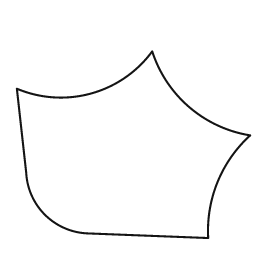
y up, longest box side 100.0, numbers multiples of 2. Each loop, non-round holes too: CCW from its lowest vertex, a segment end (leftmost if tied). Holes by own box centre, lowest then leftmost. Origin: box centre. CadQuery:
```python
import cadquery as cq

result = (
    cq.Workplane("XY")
    .moveTo(32.0, -40.0)
    .threePointArc((36.0, -16.0), (50.0, 4.0))
    .threePointArc((24.0, 16.0), (8.0, 40.0))
    .threePointArc((-18.0, 22.0), (-50.0, 24.0))
    .lineTo(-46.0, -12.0)
    .threePointArc((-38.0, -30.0), (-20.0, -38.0))
    .close()
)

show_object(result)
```